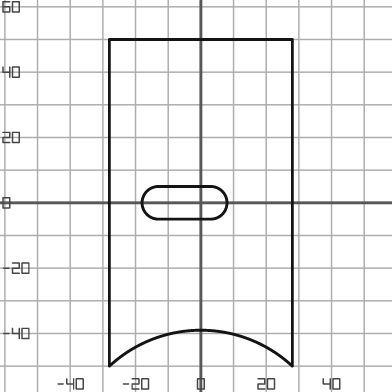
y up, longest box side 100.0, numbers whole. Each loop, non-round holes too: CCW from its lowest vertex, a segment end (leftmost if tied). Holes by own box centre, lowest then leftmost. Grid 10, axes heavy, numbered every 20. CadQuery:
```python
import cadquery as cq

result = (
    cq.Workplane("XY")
    .moveTo(-28.0, -50.0)
    .threePointArc((0.0, -39.0), (28.0, -50.0))
    .lineTo(28.0, 50.0)
    .lineTo(-28.0, 50.0)
    .close()
    .moveTo(-13.0, -5.0)
    .lineTo(3.0, -5.0)
    .threePointArc((8.0, 0.0), (3.0, 5.0))
    .lineTo(-13.0, 5.0)
    .threePointArc((-18.0, 0.0), (-13.0, -5.0))
    .close()
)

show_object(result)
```